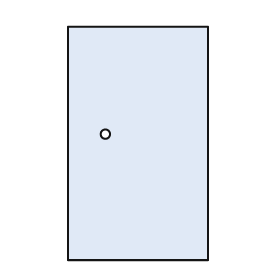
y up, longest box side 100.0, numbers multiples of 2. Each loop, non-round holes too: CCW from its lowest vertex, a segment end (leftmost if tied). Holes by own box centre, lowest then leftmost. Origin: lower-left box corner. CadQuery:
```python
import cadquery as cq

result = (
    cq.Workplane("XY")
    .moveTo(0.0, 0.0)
    .lineTo(60.0, 0.0)
    .lineTo(60.0, 100.0)
    .lineTo(0.0, 100.0)
    .close()
    .moveTo(16.0, 54.0)
    .circle(2.0)
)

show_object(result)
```